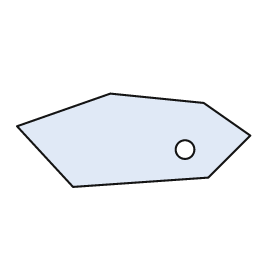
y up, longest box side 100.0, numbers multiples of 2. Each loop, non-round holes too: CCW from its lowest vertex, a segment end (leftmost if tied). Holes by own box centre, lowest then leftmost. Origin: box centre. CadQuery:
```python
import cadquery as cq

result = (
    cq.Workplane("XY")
    .moveTo(-26.0, -20.0)
    .lineTo(32.0, -16.0)
    .lineTo(50.0, 2.0)
    .lineTo(30.0, 16.0)
    .lineTo(-10.0, 20.0)
    .lineTo(-50.0, 6.0)
    .close()
    .moveTo(22.0, -4.0)
    .circle(4.0)
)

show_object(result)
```